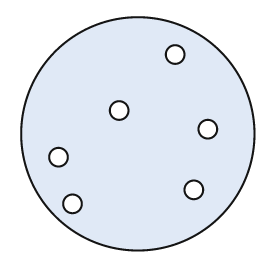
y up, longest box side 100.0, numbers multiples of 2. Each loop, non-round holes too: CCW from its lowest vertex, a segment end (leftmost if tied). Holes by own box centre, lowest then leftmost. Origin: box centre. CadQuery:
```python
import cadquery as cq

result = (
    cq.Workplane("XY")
    .moveTo(0.0, 0.0)
    .circle(50.0)
    .moveTo(-28.0, -30.0)
    .circle(4.0)
    .moveTo(24.0, -24.0)
    .circle(4.0)
    .moveTo(-34.0, -10.0)
    .circle(4.0)
    .moveTo(30.0, 2.0)
    .circle(4.0)
    .moveTo(-8.0, 10.0)
    .circle(4.0)
    .moveTo(16.0, 34.0)
    .circle(4.0)
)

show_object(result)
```